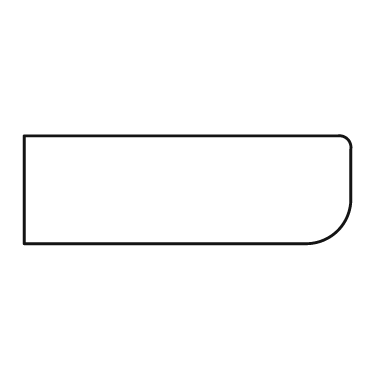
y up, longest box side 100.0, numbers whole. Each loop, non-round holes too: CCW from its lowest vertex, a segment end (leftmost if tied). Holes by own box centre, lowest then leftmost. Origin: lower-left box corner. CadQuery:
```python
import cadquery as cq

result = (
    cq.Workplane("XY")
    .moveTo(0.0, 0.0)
    .lineTo(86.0, 0.0)
    .threePointArc((96.0, 4.0), (100.0, 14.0))
    .lineTo(100.0, 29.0)
    .threePointArc((99.0, 32.0), (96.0, 33.0))
    .lineTo(0.0, 33.0)
    .close()
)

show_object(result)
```